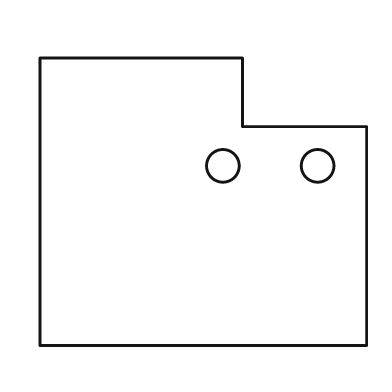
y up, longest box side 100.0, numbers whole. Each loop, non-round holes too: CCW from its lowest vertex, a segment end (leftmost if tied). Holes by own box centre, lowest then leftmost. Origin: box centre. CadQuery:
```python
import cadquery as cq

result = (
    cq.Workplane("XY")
    .moveTo(-50.0, -44.0)
    .lineTo(50.0, -44.0)
    .lineTo(50.0, 23.0)
    .lineTo(12.0, 23.0)
    .lineTo(12.0, 44.0)
    .lineTo(-50.0, 44.0)
    .close()
    .moveTo(6.0, 11.0)
    .circle(5.0)
    .moveTo(35.0, 11.0)
    .circle(5.0)
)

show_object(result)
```